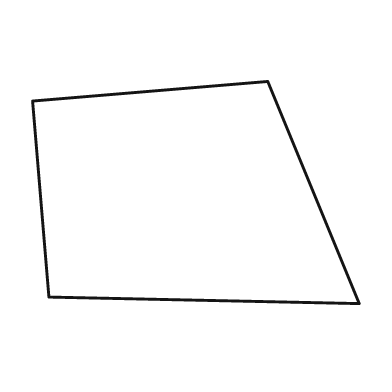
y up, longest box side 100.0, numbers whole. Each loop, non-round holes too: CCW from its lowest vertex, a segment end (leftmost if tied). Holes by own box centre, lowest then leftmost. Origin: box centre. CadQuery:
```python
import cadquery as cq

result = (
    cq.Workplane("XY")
    .moveTo(50.0, -34.0)
    .lineTo(22.0, 34.0)
    .lineTo(-50.0, 28.0)
    .lineTo(-45.0, -32.0)
    .close()
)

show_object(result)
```